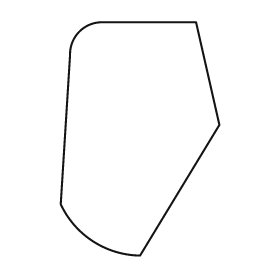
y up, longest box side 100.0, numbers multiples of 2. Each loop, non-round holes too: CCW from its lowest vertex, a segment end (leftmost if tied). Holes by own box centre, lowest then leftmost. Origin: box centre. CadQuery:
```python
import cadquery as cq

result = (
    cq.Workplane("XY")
    .moveTo(0.0, -50.0)
    .lineTo(34.0, 6.0)
    .lineTo(24.0, 50.0)
    .lineTo(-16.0, 50.0)
    .threePointArc((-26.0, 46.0), (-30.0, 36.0))
    .lineTo(-34.0, -28.0)
    .threePointArc((-20.0, -44.0), (0.0, -50.0))
    .close()
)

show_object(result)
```